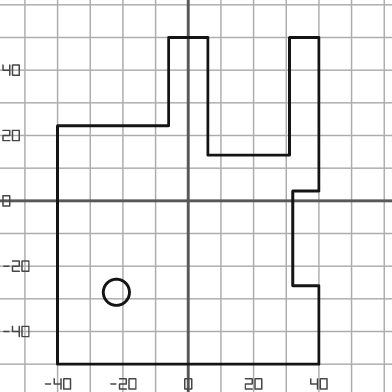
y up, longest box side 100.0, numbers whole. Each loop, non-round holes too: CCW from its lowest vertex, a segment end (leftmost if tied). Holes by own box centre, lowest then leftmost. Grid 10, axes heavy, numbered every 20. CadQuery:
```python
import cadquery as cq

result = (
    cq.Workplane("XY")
    .moveTo(-40.0, -50.0)
    .lineTo(40.0, -50.0)
    .lineTo(40.0, -26.0)
    .lineTo(32.0, -26.0)
    .lineTo(32.0, 3.0)
    .lineTo(40.0, 3.0)
    .lineTo(40.0, 50.0)
    .lineTo(31.0, 50.0)
    .lineTo(31.0, 14.0)
    .lineTo(6.0, 14.0)
    .lineTo(6.0, 50.0)
    .lineTo(-6.0, 50.0)
    .lineTo(-6.0, 23.0)
    .lineTo(-40.0, 23.0)
    .close()
    .moveTo(-22.0, -28.0)
    .circle(4.0)
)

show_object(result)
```